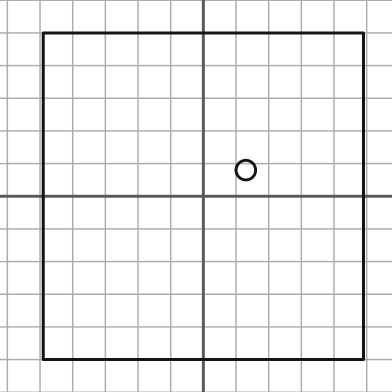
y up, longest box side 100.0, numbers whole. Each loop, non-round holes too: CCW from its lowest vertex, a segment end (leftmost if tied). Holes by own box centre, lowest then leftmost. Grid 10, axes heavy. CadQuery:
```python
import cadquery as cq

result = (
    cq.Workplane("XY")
    .moveTo(-49.0, -50.0)
    .lineTo(49.0, -50.0)
    .lineTo(49.0, 50.0)
    .lineTo(-49.0, 50.0)
    .close()
    .moveTo(13.0, 8.0)
    .circle(3.0)
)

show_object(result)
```